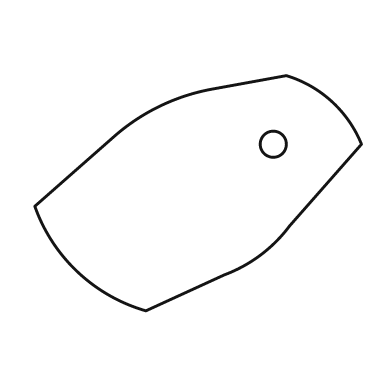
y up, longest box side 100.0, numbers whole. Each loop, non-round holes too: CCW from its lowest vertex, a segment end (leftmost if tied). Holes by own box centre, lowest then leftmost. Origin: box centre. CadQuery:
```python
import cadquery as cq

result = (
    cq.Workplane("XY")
    .moveTo(-16.0, -36.0)
    .lineTo(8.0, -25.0)
    .threePointArc((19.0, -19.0), (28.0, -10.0))
    .lineTo(50.0, 15.0)
    .threePointArc((41.0, 28.0), (27.0, 36.0))
    .lineTo(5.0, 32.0)
    .threePointArc((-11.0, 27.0), (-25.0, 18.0))
    .lineTo(-50.0, -4.0)
    .threePointArc((-37.0, -24.0), (-16.0, -36.0))
    .close()
    .moveTo(23.0, 15.0)
    .circle(4.0)
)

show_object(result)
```